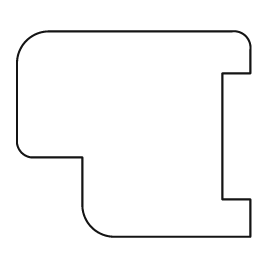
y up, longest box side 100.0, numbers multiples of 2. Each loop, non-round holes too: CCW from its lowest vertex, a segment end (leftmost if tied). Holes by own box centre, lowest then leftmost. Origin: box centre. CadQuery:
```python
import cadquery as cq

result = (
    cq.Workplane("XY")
    .moveTo(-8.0, -44.0)
    .lineTo(50.0, -44.0)
    .lineTo(50.0, -28.0)
    .lineTo(38.0, -28.0)
    .lineTo(38.0, 26.0)
    .lineTo(50.0, 26.0)
    .lineTo(50.0, 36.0)
    .threePointArc((48.0, 42.0), (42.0, 44.0))
    .lineTo(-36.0, 44.0)
    .threePointArc((-46.0, 40.0), (-50.0, 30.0))
    .lineTo(-50.0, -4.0)
    .threePointArc((-48.0, -8.0), (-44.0, -10.0))
    .lineTo(-22.0, -10.0)
    .lineTo(-22.0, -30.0)
    .threePointArc((-18.0, -40.0), (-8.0, -44.0))
    .close()
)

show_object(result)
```